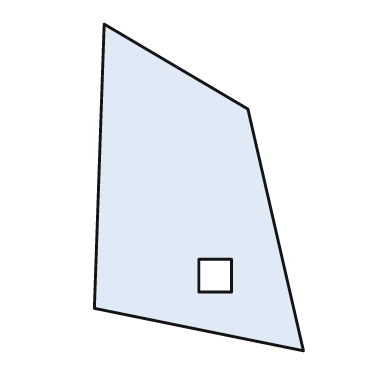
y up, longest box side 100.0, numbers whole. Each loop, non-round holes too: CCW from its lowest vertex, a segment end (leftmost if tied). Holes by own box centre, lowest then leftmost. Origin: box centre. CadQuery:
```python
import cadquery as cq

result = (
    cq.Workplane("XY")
    .moveTo(32.0, -50.0)
    .lineTo(15.0, 24.0)
    .lineTo(-29.0, 50.0)
    .lineTo(-32.0, -37.0)
    .close()
    .moveTo(0.0, -32.0)
    .lineTo(10.0, -32.0)
    .lineTo(10.0, -22.0)
    .lineTo(0.0, -22.0)
    .close()
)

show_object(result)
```